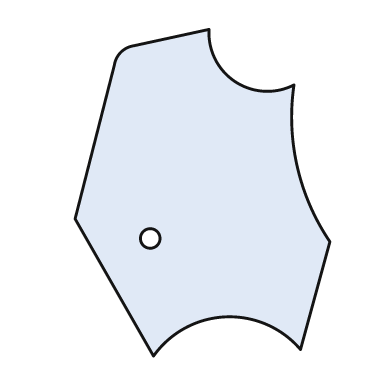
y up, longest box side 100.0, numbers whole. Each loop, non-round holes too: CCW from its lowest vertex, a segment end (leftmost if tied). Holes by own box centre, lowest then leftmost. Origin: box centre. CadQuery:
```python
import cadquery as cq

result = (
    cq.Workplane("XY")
    .moveTo(-15.0, -50.0)
    .threePointArc((7.0, -38.0), (30.0, -48.0))
    .lineTo(39.0, -15.0)
    .threePointArc((29.0, 8.0), (28.0, 33.0))
    .threePointArc((10.0, 34.0), (2.0, 50.0))
    .lineTo(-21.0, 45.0)
    .threePointArc((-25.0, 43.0), (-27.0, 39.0))
    .lineTo(-39.0, -8.0)
    .close()
    .moveTo(-16.0, -14.0)
    .circle(3.0)
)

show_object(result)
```